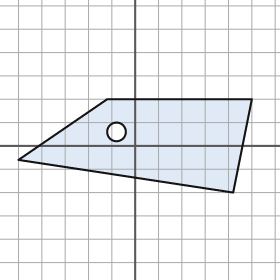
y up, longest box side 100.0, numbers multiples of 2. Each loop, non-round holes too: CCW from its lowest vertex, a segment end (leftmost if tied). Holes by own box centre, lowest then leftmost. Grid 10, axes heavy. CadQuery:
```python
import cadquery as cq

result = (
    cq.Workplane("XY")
    .moveTo(42.0, -20.0)
    .lineTo(50.0, 20.0)
    .lineTo(-12.0, 20.0)
    .lineTo(-50.0, -6.0)
    .close()
    .moveTo(-8.0, 6.0)
    .circle(4.0)
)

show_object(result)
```